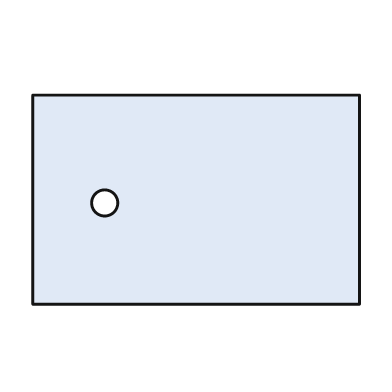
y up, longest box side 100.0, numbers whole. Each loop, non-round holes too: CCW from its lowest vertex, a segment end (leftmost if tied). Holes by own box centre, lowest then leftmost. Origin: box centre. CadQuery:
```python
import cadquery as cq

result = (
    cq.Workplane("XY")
    .moveTo(-50.0, -32.0)
    .lineTo(50.0, -32.0)
    .lineTo(50.0, 32.0)
    .lineTo(-50.0, 32.0)
    .close()
    .moveTo(-28.0, -1.0)
    .circle(4.0)
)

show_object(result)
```